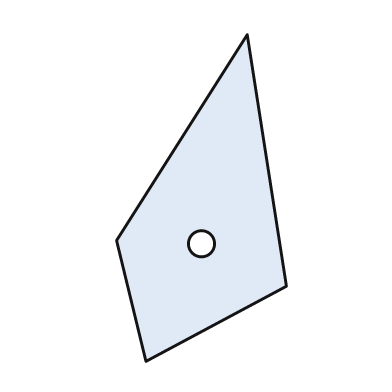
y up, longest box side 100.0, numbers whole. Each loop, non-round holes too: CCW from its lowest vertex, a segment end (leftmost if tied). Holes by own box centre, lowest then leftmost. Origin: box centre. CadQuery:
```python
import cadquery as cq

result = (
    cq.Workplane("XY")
    .moveTo(-17.0, -50.0)
    .lineTo(26.0, -27.0)
    .lineTo(14.0, 50.0)
    .lineTo(-26.0, -13.0)
    .close()
    .moveTo(0.0, -14.0)
    .circle(4.0)
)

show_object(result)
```